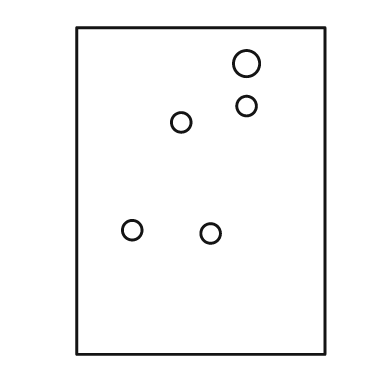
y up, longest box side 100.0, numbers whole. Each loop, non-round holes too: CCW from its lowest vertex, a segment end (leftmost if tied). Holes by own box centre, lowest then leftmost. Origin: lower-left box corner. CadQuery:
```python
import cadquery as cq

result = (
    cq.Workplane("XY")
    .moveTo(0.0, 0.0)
    .lineTo(76.0, 0.0)
    .lineTo(76.0, 100.0)
    .lineTo(0.0, 100.0)
    .close()
    .moveTo(41.0, 37.0)
    .circle(3.0)
    .moveTo(17.0, 38.0)
    .circle(3.0)
    .moveTo(32.0, 71.0)
    .circle(3.0)
    .moveTo(52.0, 76.0)
    .circle(3.0)
    .moveTo(52.0, 89.0)
    .circle(4.0)
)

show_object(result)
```